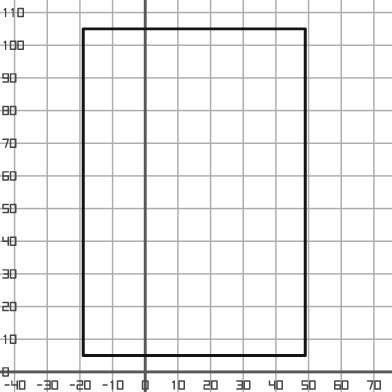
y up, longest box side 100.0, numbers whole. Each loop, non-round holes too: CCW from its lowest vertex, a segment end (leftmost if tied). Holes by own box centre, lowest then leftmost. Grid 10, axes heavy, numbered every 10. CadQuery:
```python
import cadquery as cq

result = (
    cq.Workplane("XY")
    .moveTo(-19.0, 5.0)
    .lineTo(49.0, 5.0)
    .lineTo(49.0, 105.0)
    .lineTo(-19.0, 105.0)
    .close()
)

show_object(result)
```